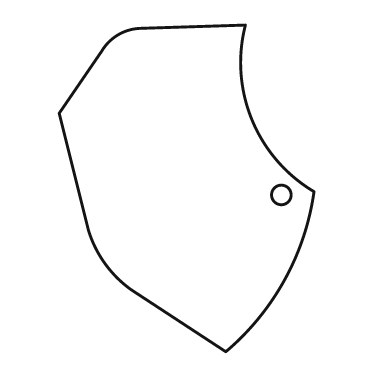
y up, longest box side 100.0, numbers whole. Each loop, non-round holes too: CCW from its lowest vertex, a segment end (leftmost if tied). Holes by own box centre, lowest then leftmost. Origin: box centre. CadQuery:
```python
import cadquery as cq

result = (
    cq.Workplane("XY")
    .moveTo(12.0, -50.0)
    .threePointArc((30.0, -28.0), (39.0, -1.0))
    .threePointArc((20.0, 21.0), (18.0, 50.0))
    .lineTo(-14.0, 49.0)
    .threePointArc((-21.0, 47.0), (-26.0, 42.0))
    .lineTo(-39.0, 23.0)
    .lineTo(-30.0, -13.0)
    .threePointArc((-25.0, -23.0), (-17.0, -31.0))
    .close()
    .moveTo(29.0, -2.0)
    .circle(3.0)
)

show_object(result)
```